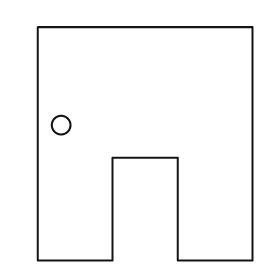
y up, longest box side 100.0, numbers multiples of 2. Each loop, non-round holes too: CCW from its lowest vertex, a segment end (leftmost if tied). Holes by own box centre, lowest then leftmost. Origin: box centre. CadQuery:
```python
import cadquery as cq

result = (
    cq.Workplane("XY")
    .moveTo(-46.0, -50.0)
    .lineTo(-14.0, -50.0)
    .lineTo(-14.0, -6.0)
    .lineTo(14.0, -6.0)
    .lineTo(14.0, -50.0)
    .lineTo(46.0, -50.0)
    .lineTo(46.0, 50.0)
    .lineTo(-46.0, 50.0)
    .close()
    .moveTo(-36.0, 8.0)
    .circle(4.0)
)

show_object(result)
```